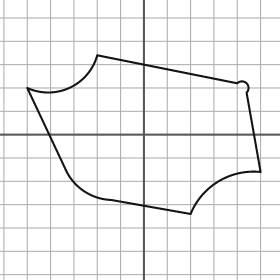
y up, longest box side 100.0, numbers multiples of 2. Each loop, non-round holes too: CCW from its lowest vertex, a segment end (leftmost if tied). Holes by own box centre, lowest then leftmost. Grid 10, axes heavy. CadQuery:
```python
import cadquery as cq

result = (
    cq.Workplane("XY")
    .moveTo(20.0, -34.0)
    .threePointArc((32.0, -20.0), (50.0, -16.0))
    .lineTo(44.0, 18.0)
    .threePointArc((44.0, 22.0), (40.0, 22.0))
    .lineTo(-20.0, 34.0)
    .threePointArc((-32.0, 20.0), (-50.0, 20.0))
    .lineTo(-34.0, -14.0)
    .threePointArc((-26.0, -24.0), (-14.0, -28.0))
    .close()
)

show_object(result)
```